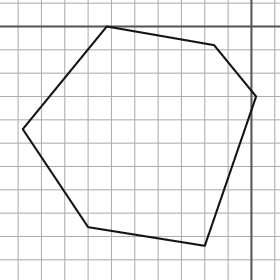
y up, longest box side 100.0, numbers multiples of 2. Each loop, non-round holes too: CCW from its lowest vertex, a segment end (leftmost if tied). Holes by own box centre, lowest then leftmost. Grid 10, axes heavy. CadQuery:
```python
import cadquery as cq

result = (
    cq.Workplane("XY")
    .moveTo(-20.0, -94.0)
    .lineTo(2.0, -30.0)
    .lineTo(-16.0, -8.0)
    .lineTo(-62.0, 0.0)
    .lineTo(-98.0, -44.0)
    .lineTo(-70.0, -86.0)
    .close()
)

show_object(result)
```